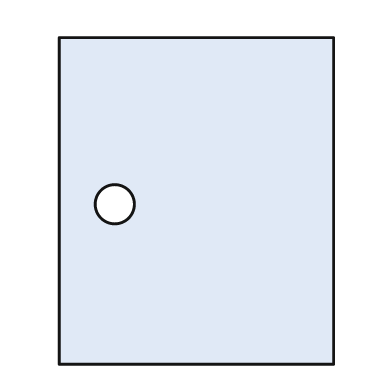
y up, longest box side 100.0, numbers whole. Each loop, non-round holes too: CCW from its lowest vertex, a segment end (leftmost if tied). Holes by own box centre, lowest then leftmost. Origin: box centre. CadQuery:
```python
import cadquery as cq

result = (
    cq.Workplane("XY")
    .moveTo(-42.0, -50.0)
    .lineTo(42.0, -50.0)
    .lineTo(42.0, 50.0)
    .lineTo(-42.0, 50.0)
    .close()
    .moveTo(-25.0, -1.0)
    .circle(6.0)
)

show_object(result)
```